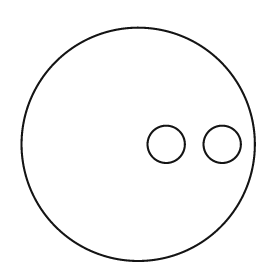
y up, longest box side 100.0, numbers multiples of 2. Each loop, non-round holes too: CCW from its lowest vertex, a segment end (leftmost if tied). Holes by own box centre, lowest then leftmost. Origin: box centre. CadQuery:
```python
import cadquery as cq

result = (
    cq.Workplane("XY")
    .moveTo(0.0, 0.0)
    .circle(50.0)
    .moveTo(12.0, 0.0)
    .circle(8.0)
    .moveTo(36.0, 0.0)
    .circle(8.0)
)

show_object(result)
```